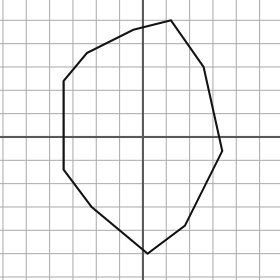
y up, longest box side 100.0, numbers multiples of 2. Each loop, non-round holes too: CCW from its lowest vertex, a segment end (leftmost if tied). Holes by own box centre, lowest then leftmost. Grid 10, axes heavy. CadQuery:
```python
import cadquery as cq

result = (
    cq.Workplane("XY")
    .moveTo(2.0, -50.0)
    .lineTo(18.0, -38.0)
    .lineTo(34.0, -6.0)
    .lineTo(26.0, 30.0)
    .lineTo(12.0, 50.0)
    .lineTo(-4.0, 46.0)
    .lineTo(-24.0, 36.0)
    .lineTo(-34.0, 24.0)
    .lineTo(-34.0, -14.0)
    .lineTo(-22.0, -30.0)
    .close()
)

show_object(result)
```